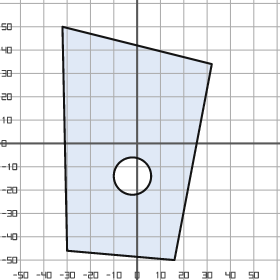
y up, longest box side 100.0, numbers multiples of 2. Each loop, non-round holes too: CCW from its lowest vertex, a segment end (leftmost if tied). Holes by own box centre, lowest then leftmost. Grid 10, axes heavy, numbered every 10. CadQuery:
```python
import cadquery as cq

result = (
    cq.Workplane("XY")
    .moveTo(16.0, -50.0)
    .lineTo(32.0, 34.0)
    .lineTo(-32.0, 50.0)
    .lineTo(-30.0, -46.0)
    .close()
    .moveTo(-2.0, -14.0)
    .circle(8.0)
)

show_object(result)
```